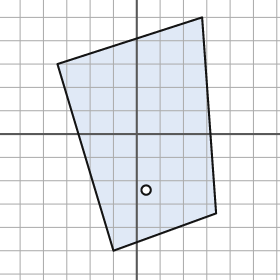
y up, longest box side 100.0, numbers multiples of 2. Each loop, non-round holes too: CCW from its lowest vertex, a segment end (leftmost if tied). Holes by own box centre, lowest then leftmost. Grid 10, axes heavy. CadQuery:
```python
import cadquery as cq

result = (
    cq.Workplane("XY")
    .moveTo(-10.0, -50.0)
    .lineTo(34.0, -34.0)
    .lineTo(28.0, 50.0)
    .lineTo(-34.0, 30.0)
    .close()
    .moveTo(4.0, -24.0)
    .circle(2.0)
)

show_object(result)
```